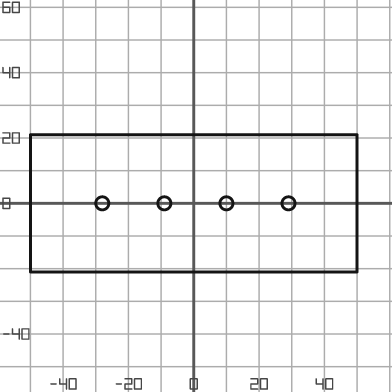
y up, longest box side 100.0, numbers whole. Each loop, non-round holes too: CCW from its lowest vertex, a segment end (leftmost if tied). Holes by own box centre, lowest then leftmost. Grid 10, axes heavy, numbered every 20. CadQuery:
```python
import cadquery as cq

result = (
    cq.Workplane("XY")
    .moveTo(-50.0, -21.0)
    .lineTo(50.0, -21.0)
    .lineTo(50.0, 21.0)
    .lineTo(-50.0, 21.0)
    .close()
    .moveTo(-28.0, 0.0)
    .circle(2.0)
    .moveTo(-9.0, 0.0)
    .circle(2.0)
    .moveTo(10.0, 0.0)
    .circle(2.0)
    .moveTo(29.0, 0.0)
    .circle(2.0)
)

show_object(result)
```